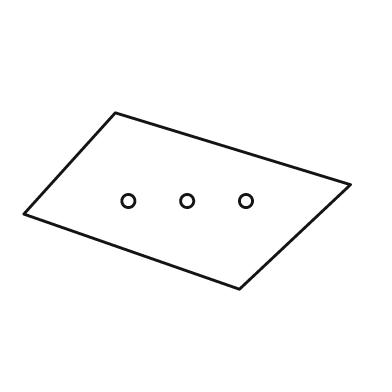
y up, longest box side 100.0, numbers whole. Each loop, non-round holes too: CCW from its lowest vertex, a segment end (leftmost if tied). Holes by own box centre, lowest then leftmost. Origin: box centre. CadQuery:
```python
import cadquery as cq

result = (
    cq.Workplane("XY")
    .moveTo(16.0, -27.0)
    .lineTo(50.0, 5.0)
    .lineTo(-22.0, 27.0)
    .lineTo(-50.0, -4.0)
    .close()
    .moveTo(-18.0, 0.0)
    .circle(2.0)
    .moveTo(0.0, 0.0)
    .circle(2.0)
    .moveTo(18.0, 0.0)
    .circle(2.0)
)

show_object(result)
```